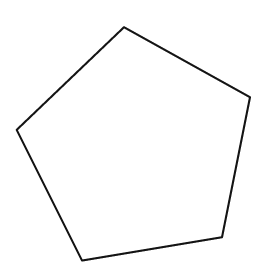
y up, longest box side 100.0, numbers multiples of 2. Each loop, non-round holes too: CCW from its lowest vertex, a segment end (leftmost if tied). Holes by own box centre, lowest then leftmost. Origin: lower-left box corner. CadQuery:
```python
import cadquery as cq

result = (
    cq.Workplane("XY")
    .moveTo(28.0, 0.0)
    .lineTo(88.0, 10.0)
    .lineTo(100.0, 70.0)
    .lineTo(46.0, 100.0)
    .lineTo(0.0, 56.0)
    .close()
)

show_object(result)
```